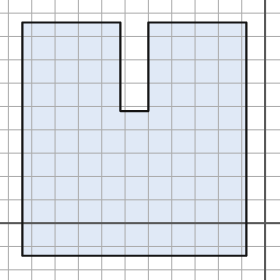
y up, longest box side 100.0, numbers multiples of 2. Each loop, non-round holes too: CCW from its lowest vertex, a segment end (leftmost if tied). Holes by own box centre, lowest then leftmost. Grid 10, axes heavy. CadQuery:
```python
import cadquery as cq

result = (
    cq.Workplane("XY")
    .moveTo(-104.0, -14.0)
    .lineTo(-8.0, -14.0)
    .lineTo(-8.0, 86.0)
    .lineTo(-50.0, 86.0)
    .lineTo(-50.0, 48.0)
    .lineTo(-62.0, 48.0)
    .lineTo(-62.0, 86.0)
    .lineTo(-104.0, 86.0)
    .close()
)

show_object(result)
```